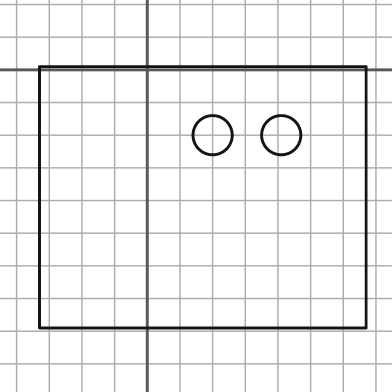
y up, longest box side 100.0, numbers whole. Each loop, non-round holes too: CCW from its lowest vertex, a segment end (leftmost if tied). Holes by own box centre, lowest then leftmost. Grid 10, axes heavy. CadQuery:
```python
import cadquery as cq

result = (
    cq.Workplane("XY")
    .moveTo(-33.0, -79.0)
    .lineTo(67.0, -79.0)
    .lineTo(67.0, 1.0)
    .lineTo(-33.0, 1.0)
    .close()
    .moveTo(20.0, -20.0)
    .circle(6.0)
    .moveTo(41.0, -20.0)
    .circle(6.0)
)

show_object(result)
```